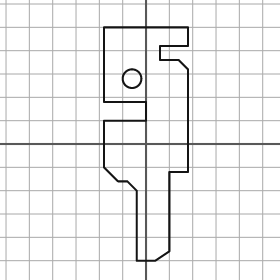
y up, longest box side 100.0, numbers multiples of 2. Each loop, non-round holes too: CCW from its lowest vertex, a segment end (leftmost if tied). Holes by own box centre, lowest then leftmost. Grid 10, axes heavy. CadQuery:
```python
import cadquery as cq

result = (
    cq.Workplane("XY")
    .moveTo(-4.0, -50.0)
    .lineTo(4.0, -50.0)
    .lineTo(10.0, -46.0)
    .lineTo(10.0, -12.0)
    .lineTo(18.0, -12.0)
    .lineTo(18.0, 32.0)
    .lineTo(14.0, 36.0)
    .lineTo(6.0, 36.0)
    .lineTo(6.0, 42.0)
    .lineTo(18.0, 42.0)
    .lineTo(18.0, 50.0)
    .lineTo(-18.0, 50.0)
    .lineTo(-18.0, 18.0)
    .lineTo(0.0, 18.0)
    .lineTo(0.0, 10.0)
    .lineTo(-18.0, 10.0)
    .lineTo(-18.0, -10.0)
    .lineTo(-12.0, -16.0)
    .lineTo(-8.0, -16.0)
    .lineTo(-4.0, -20.0)
    .close()
    .moveTo(-6.0, 28.0)
    .circle(4.0)
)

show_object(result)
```